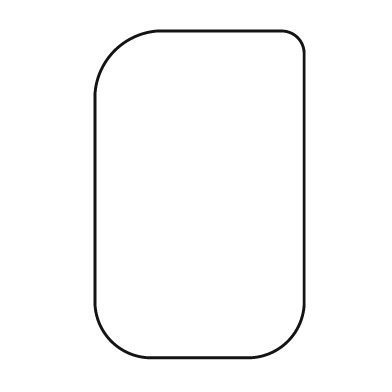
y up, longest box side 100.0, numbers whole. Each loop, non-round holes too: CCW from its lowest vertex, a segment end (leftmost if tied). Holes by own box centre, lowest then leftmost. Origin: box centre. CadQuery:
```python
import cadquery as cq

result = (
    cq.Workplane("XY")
    .moveTo(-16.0, -50.0)
    .lineTo(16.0, -50.0)
    .threePointArc((27.0, -45.0), (32.0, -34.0))
    .lineTo(32.0, 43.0)
    .threePointArc((30.0, 48.0), (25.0, 50.0))
    .lineTo(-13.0, 50.0)
    .threePointArc((-26.0, 44.0), (-32.0, 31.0))
    .lineTo(-32.0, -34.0)
    .threePointArc((-27.0, -45.0), (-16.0, -50.0))
    .close()
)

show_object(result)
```